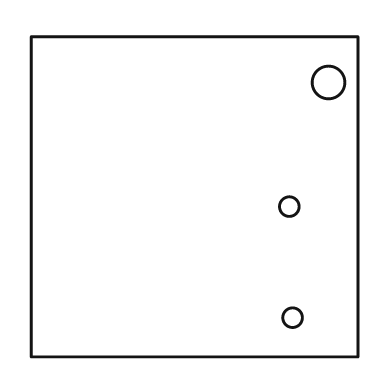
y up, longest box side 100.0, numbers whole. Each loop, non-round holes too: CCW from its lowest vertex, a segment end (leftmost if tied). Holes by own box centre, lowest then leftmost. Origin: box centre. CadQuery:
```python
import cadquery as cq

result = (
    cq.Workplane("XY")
    .moveTo(-50.0, -49.0)
    .lineTo(50.0, -49.0)
    .lineTo(50.0, 49.0)
    .lineTo(-50.0, 49.0)
    .close()
    .moveTo(30.0, -37.0)
    .circle(3.0)
    .moveTo(29.0, -3.0)
    .circle(3.0)
    .moveTo(41.0, 35.0)
    .circle(5.0)
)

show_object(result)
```